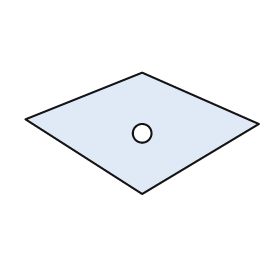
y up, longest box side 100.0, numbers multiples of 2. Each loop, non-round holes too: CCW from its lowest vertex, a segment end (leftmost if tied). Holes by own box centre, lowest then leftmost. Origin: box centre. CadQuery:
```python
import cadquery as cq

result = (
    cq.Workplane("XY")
    .moveTo(0.0, -26.0)
    .lineTo(50.0, 4.0)
    .lineTo(0.0, 26.0)
    .lineTo(-50.0, 6.0)
    .close()
    .moveTo(0.0, 0.0)
    .circle(4.0)
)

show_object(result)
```